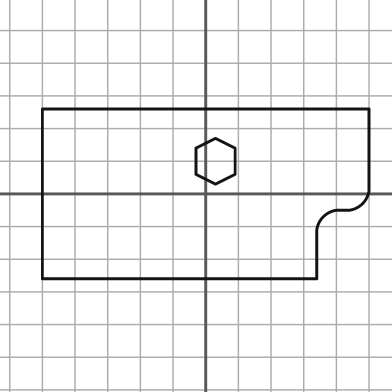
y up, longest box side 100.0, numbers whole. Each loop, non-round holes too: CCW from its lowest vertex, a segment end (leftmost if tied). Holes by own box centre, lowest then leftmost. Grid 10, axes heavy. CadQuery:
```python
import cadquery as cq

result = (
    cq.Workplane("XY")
    .moveTo(-50.0, -26.0)
    .lineTo(34.0, -26.0)
    .lineTo(34.0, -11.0)
    .threePointArc((36.0, -7.0), (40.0, -5.0))
    .lineTo(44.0, -5.0)
    .threePointArc((48.0, -3.0), (50.0, 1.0))
    .lineTo(50.0, 26.0)
    .lineTo(-50.0, 26.0)
    .close()
    .moveTo(3.0, 3.0)
    .lineTo(9.0, 6.0)
    .lineTo(9.0, 14.0)
    .lineTo(3.0, 17.0)
    .lineTo(-3.0, 14.0)
    .lineTo(-3.0, 6.0)
    .close()
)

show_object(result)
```